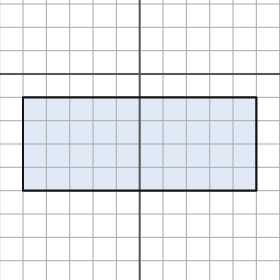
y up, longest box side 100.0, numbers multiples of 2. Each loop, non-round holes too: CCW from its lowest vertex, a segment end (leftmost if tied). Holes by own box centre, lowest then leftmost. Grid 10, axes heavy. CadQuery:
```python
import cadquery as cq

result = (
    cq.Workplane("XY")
    .moveTo(-50.0, -50.0)
    .lineTo(50.0, -50.0)
    .lineTo(50.0, -10.0)
    .lineTo(-50.0, -10.0)
    .close()
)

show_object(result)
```